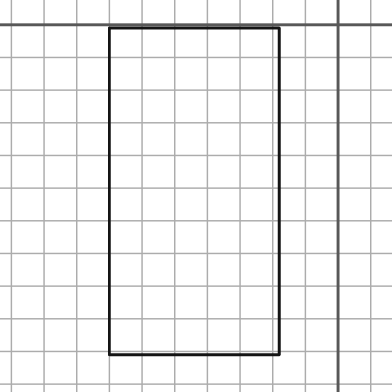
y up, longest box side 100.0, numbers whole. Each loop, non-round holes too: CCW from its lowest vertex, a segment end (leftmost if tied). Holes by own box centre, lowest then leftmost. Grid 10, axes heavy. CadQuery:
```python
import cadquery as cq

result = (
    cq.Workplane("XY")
    .moveTo(-70.0, -101.0)
    .lineTo(-18.0, -101.0)
    .lineTo(-18.0, -1.0)
    .lineTo(-70.0, -1.0)
    .close()
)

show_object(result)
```